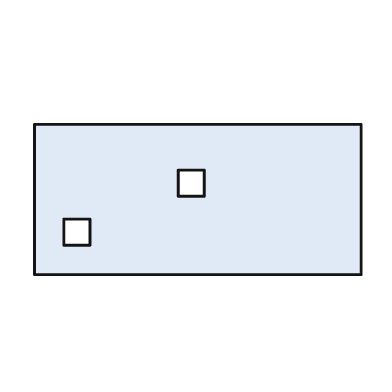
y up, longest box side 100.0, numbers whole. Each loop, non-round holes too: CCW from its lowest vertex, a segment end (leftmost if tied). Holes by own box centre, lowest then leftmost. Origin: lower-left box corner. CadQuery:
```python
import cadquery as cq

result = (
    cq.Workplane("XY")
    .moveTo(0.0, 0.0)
    .lineTo(100.0, 0.0)
    .lineTo(100.0, 46.0)
    .lineTo(0.0, 46.0)
    .close()
    .moveTo(9.0, 9.0)
    .lineTo(17.0, 9.0)
    .lineTo(17.0, 17.0)
    .lineTo(9.0, 17.0)
    .close()
    .moveTo(44.0, 24.0)
    .lineTo(52.0, 24.0)
    .lineTo(52.0, 32.0)
    .lineTo(44.0, 32.0)
    .close()
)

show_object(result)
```